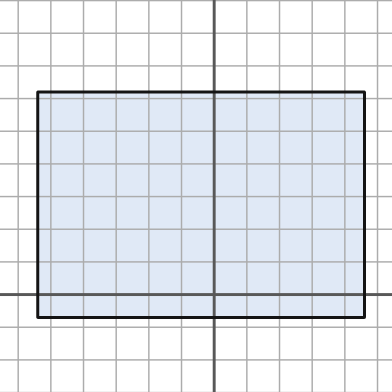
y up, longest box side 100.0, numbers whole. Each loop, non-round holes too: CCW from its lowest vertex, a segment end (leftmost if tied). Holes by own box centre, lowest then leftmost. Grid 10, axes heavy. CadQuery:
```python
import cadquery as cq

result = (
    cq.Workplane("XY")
    .moveTo(-54.0, -7.0)
    .lineTo(46.0, -7.0)
    .lineTo(46.0, 62.0)
    .lineTo(-54.0, 62.0)
    .close()
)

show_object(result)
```